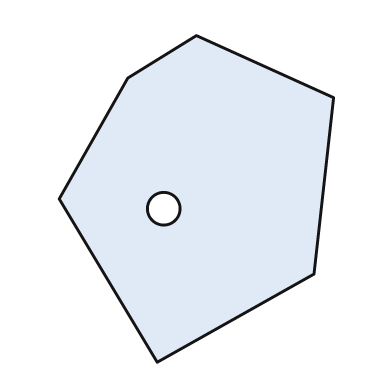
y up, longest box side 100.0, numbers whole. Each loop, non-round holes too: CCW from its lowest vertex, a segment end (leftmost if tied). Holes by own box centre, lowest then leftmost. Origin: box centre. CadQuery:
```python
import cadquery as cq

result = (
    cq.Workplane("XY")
    .moveTo(-12.0, -50.0)
    .lineTo(36.0, -23.0)
    .lineTo(42.0, 31.0)
    .lineTo(0.0, 50.0)
    .lineTo(-21.0, 37.0)
    .lineTo(-42.0, 0.0)
    .close()
    .moveTo(-10.0, -3.0)
    .circle(5.0)
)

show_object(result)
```